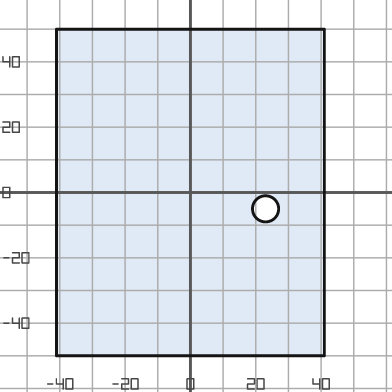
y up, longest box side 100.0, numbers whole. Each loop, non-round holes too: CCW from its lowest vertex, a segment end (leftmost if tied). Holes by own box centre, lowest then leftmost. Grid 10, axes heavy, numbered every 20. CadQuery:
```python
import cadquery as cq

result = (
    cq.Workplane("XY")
    .moveTo(-41.0, -50.0)
    .lineTo(41.0, -50.0)
    .lineTo(41.0, 50.0)
    .lineTo(-41.0, 50.0)
    .close()
    .moveTo(23.0, -5.0)
    .circle(4.0)
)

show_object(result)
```